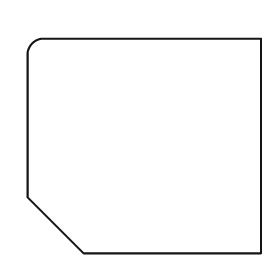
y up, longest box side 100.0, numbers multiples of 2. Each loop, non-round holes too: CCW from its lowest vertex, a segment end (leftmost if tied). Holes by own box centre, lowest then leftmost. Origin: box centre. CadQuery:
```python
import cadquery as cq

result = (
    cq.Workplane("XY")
    .moveTo(-26.0, -46.0)
    .lineTo(50.0, -46.0)
    .lineTo(50.0, 46.0)
    .lineTo(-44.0, 46.0)
    .threePointArc((-48.0, 44.0), (-50.0, 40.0))
    .lineTo(-50.0, -22.0)
    .close()
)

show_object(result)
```